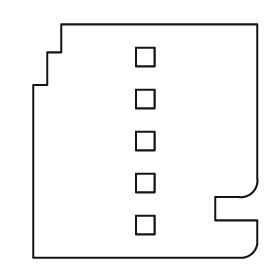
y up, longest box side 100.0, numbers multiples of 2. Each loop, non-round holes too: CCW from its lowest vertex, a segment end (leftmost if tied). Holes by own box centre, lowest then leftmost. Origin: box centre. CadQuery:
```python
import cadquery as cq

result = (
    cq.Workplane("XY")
    .moveTo(-48.0, -50.0)
    .lineTo(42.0, -50.0)
    .threePointArc((46.0, -48.0), (48.0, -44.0))
    .lineTo(48.0, -34.0)
    .lineTo(30.0, -34.0)
    .lineTo(30.0, -24.0)
    .lineTo(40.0, -24.0)
    .threePointArc((46.0, -22.0), (48.0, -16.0))
    .lineTo(48.0, 50.0)
    .lineTo(-36.0, 50.0)
    .lineTo(-36.0, 38.0)
    .lineTo(-42.0, 38.0)
    .lineTo(-42.0, 24.0)
    .lineTo(-48.0, 24.0)
    .close()
    .moveTo(-4.0, -40.0)
    .lineTo(4.0, -40.0)
    .lineTo(4.0, -32.0)
    .lineTo(-4.0, -32.0)
    .close()
    .moveTo(-4.0, -22.0)
    .lineTo(4.0, -22.0)
    .lineTo(4.0, -14.0)
    .lineTo(-4.0, -14.0)
    .close()
    .moveTo(-4.0, -4.0)
    .lineTo(4.0, -4.0)
    .lineTo(4.0, 4.0)
    .lineTo(-4.0, 4.0)
    .close()
    .moveTo(-4.0, 14.0)
    .lineTo(4.0, 14.0)
    .lineTo(4.0, 22.0)
    .lineTo(-4.0, 22.0)
    .close()
    .moveTo(-4.0, 32.0)
    .lineTo(4.0, 32.0)
    .lineTo(4.0, 40.0)
    .lineTo(-4.0, 40.0)
    .close()
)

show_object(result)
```